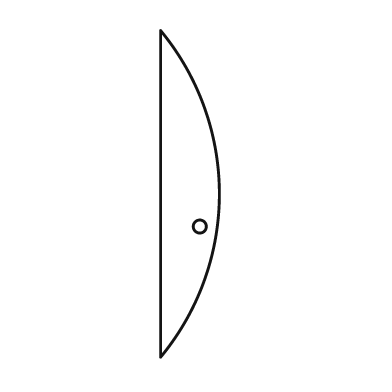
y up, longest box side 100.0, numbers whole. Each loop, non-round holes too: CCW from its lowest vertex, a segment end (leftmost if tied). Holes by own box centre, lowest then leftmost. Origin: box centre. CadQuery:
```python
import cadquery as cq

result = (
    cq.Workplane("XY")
    .moveTo(-9.0, -50.0)
    .threePointArc((9.0, 0.0), (-9.0, 50.0))
    .close()
    .moveTo(3.0, -10.0)
    .circle(2.0)
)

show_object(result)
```